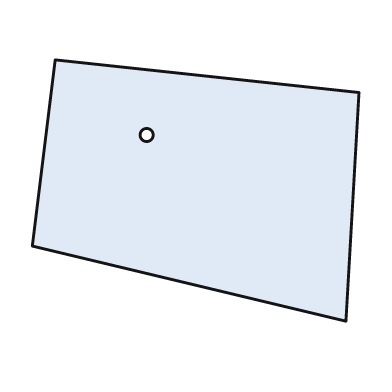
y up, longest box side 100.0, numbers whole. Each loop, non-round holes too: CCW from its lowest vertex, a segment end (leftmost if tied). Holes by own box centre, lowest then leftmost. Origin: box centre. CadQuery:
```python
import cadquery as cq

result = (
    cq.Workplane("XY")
    .moveTo(46.0, -40.0)
    .lineTo(50.0, 30.0)
    .lineTo(-43.0, 40.0)
    .lineTo(-50.0, -17.0)
    .close()
    .moveTo(-15.0, 17.0)
    .circle(2.0)
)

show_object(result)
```